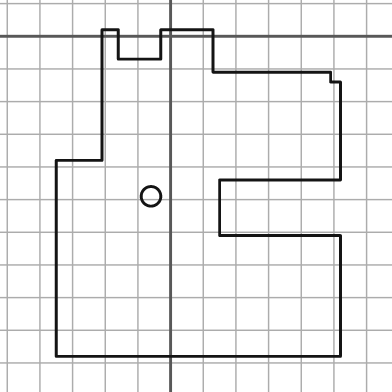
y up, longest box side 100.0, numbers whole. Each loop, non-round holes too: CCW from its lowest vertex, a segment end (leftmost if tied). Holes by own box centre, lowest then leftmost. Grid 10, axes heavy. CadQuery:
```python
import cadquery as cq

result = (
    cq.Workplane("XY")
    .moveTo(-35.0, -98.0)
    .lineTo(52.0, -98.0)
    .lineTo(52.0, -61.0)
    .lineTo(15.0, -61.0)
    .lineTo(15.0, -44.0)
    .lineTo(52.0, -44.0)
    .lineTo(52.0, -14.0)
    .lineTo(49.0, -14.0)
    .lineTo(49.0, -11.0)
    .lineTo(13.0, -11.0)
    .lineTo(13.0, 2.0)
    .lineTo(-3.0, 2.0)
    .lineTo(-3.0, -7.0)
    .lineTo(-16.0, -7.0)
    .lineTo(-16.0, 2.0)
    .lineTo(-21.0, 2.0)
    .lineTo(-21.0, -38.0)
    .lineTo(-35.0, -38.0)
    .close()
    .moveTo(-6.0, -49.0)
    .circle(3.0)
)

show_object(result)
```